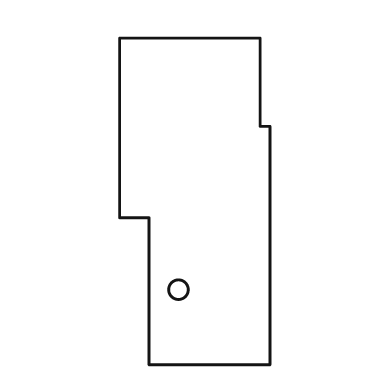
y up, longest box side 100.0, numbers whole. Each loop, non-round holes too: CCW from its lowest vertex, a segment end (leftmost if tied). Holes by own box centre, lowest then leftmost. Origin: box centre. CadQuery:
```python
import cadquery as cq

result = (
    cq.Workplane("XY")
    .moveTo(-14.0, -50.0)
    .lineTo(23.0, -50.0)
    .lineTo(23.0, 23.0)
    .lineTo(20.0, 23.0)
    .lineTo(20.0, 50.0)
    .lineTo(-23.0, 50.0)
    .lineTo(-23.0, -5.0)
    .lineTo(-14.0, -5.0)
    .close()
    .moveTo(-5.0, -27.0)
    .circle(3.0)
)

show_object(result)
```